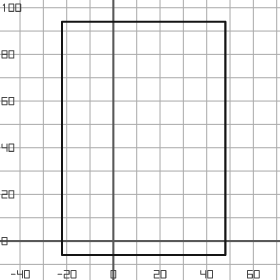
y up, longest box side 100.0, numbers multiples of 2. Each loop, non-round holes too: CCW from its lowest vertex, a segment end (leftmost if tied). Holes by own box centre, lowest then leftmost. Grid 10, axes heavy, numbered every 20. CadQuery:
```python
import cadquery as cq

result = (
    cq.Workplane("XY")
    .moveTo(-22.0, -6.0)
    .lineTo(48.0, -6.0)
    .lineTo(48.0, 94.0)
    .lineTo(-22.0, 94.0)
    .close()
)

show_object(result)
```